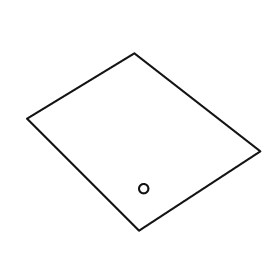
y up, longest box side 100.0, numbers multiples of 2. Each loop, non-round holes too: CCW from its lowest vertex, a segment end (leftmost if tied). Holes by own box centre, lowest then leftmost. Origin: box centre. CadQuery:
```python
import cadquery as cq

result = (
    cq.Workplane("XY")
    .moveTo(-2.0, -38.0)
    .lineTo(50.0, -4.0)
    .lineTo(-4.0, 38.0)
    .lineTo(-50.0, 10.0)
    .close()
    .moveTo(0.0, -20.0)
    .circle(2.0)
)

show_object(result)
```